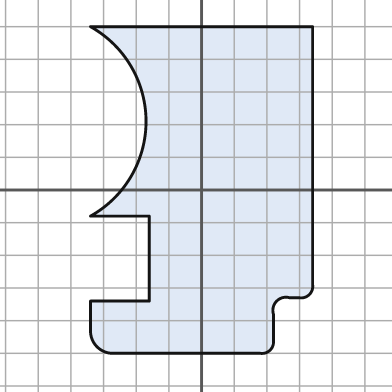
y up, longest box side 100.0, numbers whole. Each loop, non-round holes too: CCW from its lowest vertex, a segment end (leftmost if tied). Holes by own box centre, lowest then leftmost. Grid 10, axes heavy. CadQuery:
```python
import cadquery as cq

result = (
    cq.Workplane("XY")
    .moveTo(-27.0, -50.0)
    .lineTo(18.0, -50.0)
    .threePointArc((21.0, -49.0), (22.0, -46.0))
    .lineTo(22.0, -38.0)
    .threePointArc((23.0, -34.0), (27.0, -33.0))
    .lineTo(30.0, -33.0)
    .threePointArc((33.0, -32.0), (34.0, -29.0))
    .lineTo(34.0, 50.0)
    .lineTo(-34.0, 50.0)
    .threePointArc((-17.0, 21.0), (-34.0, -8.0))
    .lineTo(-16.0, -8.0)
    .lineTo(-16.0, -34.0)
    .lineTo(-34.0, -34.0)
    .lineTo(-34.0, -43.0)
    .threePointArc((-32.0, -48.0), (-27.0, -50.0))
    .close()
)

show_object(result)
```